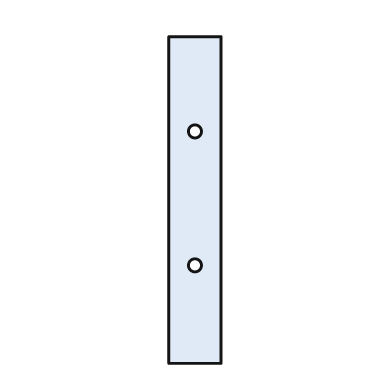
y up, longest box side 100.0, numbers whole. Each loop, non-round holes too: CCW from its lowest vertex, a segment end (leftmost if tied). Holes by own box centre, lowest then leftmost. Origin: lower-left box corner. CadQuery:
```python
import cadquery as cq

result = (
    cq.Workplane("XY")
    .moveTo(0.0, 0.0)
    .lineTo(16.0, 0.0)
    .lineTo(16.0, 100.0)
    .lineTo(0.0, 100.0)
    .close()
    .moveTo(8.0, 30.0)
    .circle(2.0)
    .moveTo(8.0, 71.0)
    .circle(2.0)
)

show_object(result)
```